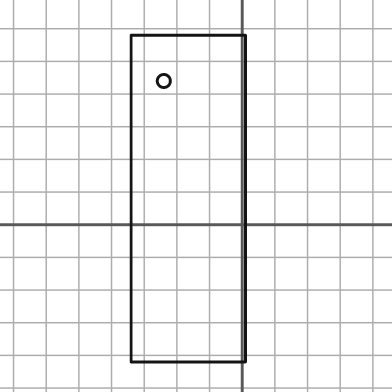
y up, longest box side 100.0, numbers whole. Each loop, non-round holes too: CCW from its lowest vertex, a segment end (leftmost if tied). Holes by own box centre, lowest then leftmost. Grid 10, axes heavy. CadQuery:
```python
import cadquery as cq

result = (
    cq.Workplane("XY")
    .moveTo(-34.0, -42.0)
    .lineTo(1.0, -42.0)
    .lineTo(1.0, 58.0)
    .lineTo(-34.0, 58.0)
    .close()
    .moveTo(-24.0, 44.0)
    .circle(2.0)
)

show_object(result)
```